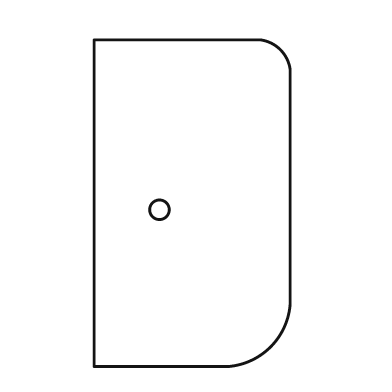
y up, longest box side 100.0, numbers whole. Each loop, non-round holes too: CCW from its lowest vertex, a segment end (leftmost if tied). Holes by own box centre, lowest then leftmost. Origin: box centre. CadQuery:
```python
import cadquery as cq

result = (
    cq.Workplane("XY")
    .moveTo(-30.0, -50.0)
    .lineTo(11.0, -50.0)
    .threePointArc((24.0, -44.0), (30.0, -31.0))
    .lineTo(30.0, 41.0)
    .threePointArc((27.0, 47.0), (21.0, 50.0))
    .lineTo(-30.0, 50.0)
    .close()
    .moveTo(-10.0, -2.0)
    .circle(3.0)
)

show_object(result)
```